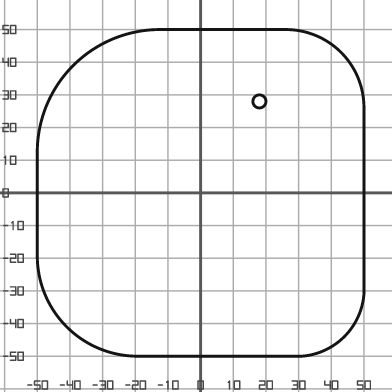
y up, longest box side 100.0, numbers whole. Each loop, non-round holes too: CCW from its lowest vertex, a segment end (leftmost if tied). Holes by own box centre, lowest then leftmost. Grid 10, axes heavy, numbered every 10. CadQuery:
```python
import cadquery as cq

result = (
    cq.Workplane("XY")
    .moveTo(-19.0, -50.0)
    .lineTo(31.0, -50.0)
    .threePointArc((44.0, -44.0), (50.0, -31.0))
    .lineTo(50.0, 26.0)
    .threePointArc((43.0, 43.0), (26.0, 50.0))
    .lineTo(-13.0, 50.0)
    .threePointArc((-39.0, 39.0), (-50.0, 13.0))
    .lineTo(-50.0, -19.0)
    .threePointArc((-41.0, -41.0), (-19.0, -50.0))
    .close()
    .moveTo(18.0, 28.0)
    .circle(2.0)
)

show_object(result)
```